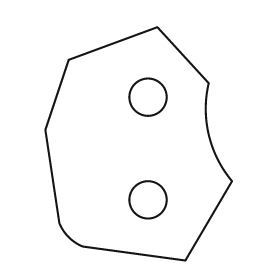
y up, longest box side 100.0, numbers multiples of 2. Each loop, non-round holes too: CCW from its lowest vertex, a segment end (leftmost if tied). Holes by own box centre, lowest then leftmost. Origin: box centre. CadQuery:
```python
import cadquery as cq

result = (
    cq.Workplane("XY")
    .moveTo(20.0, -50.0)
    .lineTo(40.0, -16.0)
    .threePointArc((30.0, 4.0), (30.0, 26.0))
    .lineTo(8.0, 50.0)
    .lineTo(-30.0, 36.0)
    .lineTo(-40.0, 6.0)
    .lineTo(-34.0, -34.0)
    .threePointArc((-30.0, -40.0), (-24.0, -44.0))
    .close()
    .moveTo(4.0, -24.0)
    .circle(8.0)
    .moveTo(4.0, 20.0)
    .circle(8.0)
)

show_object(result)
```